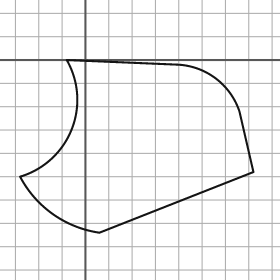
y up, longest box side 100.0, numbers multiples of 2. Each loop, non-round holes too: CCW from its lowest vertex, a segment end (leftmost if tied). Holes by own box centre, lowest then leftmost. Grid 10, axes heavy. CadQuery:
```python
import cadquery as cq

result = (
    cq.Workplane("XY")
    .moveTo(6.0, -74.0)
    .lineTo(72.0, -48.0)
    .lineTo(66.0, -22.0)
    .threePointArc((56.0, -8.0), (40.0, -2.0))
    .lineTo(-8.0, 0.0)
    .threePointArc((-6.0, -30.0), (-28.0, -50.0))
    .threePointArc((-14.0, -66.0), (6.0, -74.0))
    .close()
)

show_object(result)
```